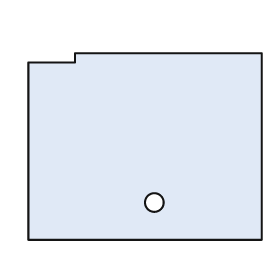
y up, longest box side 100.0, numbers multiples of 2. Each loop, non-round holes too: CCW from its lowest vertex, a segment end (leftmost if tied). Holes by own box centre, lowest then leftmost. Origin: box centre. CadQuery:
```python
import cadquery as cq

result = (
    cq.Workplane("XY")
    .moveTo(-50.0, -40.0)
    .lineTo(50.0, -40.0)
    .lineTo(50.0, 40.0)
    .lineTo(-30.0, 40.0)
    .lineTo(-30.0, 36.0)
    .lineTo(-50.0, 36.0)
    .close()
    .moveTo(4.0, -24.0)
    .circle(4.0)
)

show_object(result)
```